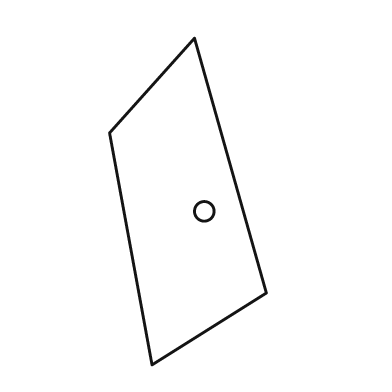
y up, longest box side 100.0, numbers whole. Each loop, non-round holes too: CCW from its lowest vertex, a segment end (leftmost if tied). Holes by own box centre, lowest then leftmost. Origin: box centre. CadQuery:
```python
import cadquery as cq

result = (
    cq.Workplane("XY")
    .moveTo(-11.0, -50.0)
    .lineTo(24.0, -28.0)
    .lineTo(2.0, 50.0)
    .lineTo(-24.0, 21.0)
    .close()
    .moveTo(5.0, -3.0)
    .circle(3.0)
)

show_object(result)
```